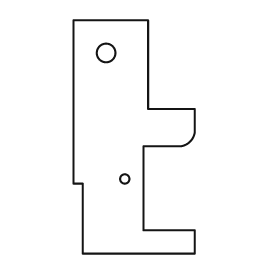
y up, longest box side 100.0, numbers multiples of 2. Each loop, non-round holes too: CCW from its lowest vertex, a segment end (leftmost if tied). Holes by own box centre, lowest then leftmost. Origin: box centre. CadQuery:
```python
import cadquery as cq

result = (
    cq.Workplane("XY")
    .moveTo(-22.0, -50.0)
    .lineTo(26.0, -50.0)
    .lineTo(26.0, -40.0)
    .lineTo(4.0, -40.0)
    .lineTo(4.0, -4.0)
    .lineTo(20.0, -4.0)
    .threePointArc((24.0, -2.0), (26.0, 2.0))
    .lineTo(26.0, 12.0)
    .lineTo(6.0, 12.0)
    .lineTo(6.0, 50.0)
    .lineTo(-26.0, 50.0)
    .lineTo(-26.0, -20.0)
    .lineTo(-22.0, -20.0)
    .close()
    .moveTo(-4.0, -18.0)
    .circle(2.0)
    .moveTo(-12.0, 36.0)
    .circle(4.0)
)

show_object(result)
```